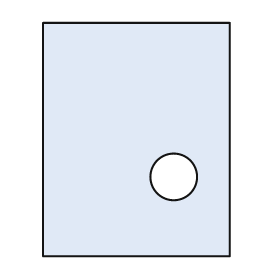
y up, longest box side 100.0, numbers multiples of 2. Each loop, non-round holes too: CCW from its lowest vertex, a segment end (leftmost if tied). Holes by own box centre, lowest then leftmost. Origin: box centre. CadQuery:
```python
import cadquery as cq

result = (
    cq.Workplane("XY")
    .moveTo(-40.0, -50.0)
    .lineTo(40.0, -50.0)
    .lineTo(40.0, 50.0)
    .lineTo(-40.0, 50.0)
    .close()
    .moveTo(16.0, -16.0)
    .circle(10.0)
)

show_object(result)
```